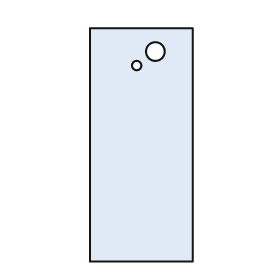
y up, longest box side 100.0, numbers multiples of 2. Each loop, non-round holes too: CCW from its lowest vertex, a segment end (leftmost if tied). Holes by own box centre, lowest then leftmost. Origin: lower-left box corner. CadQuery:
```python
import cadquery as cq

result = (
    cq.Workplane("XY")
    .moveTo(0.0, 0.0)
    .lineTo(44.0, 0.0)
    .lineTo(44.0, 100.0)
    .lineTo(0.0, 100.0)
    .close()
    .moveTo(20.0, 84.0)
    .circle(2.0)
    .moveTo(28.0, 90.0)
    .circle(4.0)
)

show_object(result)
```